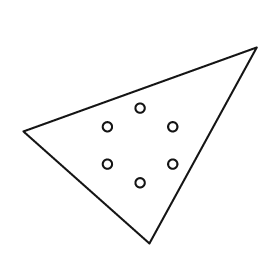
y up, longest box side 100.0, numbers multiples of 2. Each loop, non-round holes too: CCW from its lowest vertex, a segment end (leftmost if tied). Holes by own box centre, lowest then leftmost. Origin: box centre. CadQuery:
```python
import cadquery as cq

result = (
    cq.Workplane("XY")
    .moveTo(4.0, -42.0)
    .lineTo(50.0, 42.0)
    .lineTo(-50.0, 6.0)
    .close()
    .moveTo(0.0, -16.0)
    .circle(2.0)
    .moveTo(-14.0, -8.0)
    .circle(2.0)
    .moveTo(14.0, -8.0)
    .circle(2.0)
    .moveTo(-14.0, 8.0)
    .circle(2.0)
    .moveTo(14.0, 8.0)
    .circle(2.0)
    .moveTo(0.0, 16.0)
    .circle(2.0)
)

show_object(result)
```